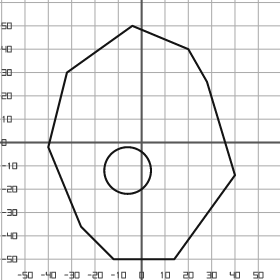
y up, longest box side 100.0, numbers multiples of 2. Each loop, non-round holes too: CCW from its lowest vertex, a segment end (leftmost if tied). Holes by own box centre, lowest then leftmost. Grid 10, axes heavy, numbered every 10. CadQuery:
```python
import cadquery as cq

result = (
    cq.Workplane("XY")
    .moveTo(-12.0, -50.0)
    .lineTo(14.0, -50.0)
    .lineTo(40.0, -14.0)
    .lineTo(28.0, 26.0)
    .lineTo(20.0, 40.0)
    .lineTo(-4.0, 50.0)
    .lineTo(-32.0, 30.0)
    .lineTo(-40.0, -2.0)
    .lineTo(-26.0, -36.0)
    .close()
    .moveTo(-6.0, -12.0)
    .circle(10.0)
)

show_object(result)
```